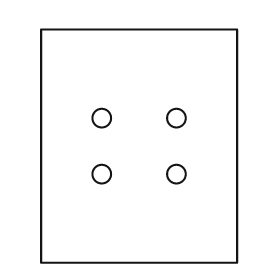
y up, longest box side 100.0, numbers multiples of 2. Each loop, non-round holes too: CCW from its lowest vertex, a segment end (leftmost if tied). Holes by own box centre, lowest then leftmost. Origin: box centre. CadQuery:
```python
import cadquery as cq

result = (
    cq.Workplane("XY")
    .moveTo(-42.0, -50.0)
    .lineTo(42.0, -50.0)
    .lineTo(42.0, 50.0)
    .lineTo(-42.0, 50.0)
    .close()
    .moveTo(-16.0, -12.0)
    .circle(4.0)
    .moveTo(16.0, -12.0)
    .circle(4.0)
    .moveTo(-16.0, 12.0)
    .circle(4.0)
    .moveTo(16.0, 12.0)
    .circle(4.0)
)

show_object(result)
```